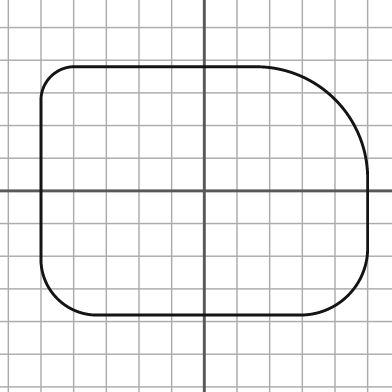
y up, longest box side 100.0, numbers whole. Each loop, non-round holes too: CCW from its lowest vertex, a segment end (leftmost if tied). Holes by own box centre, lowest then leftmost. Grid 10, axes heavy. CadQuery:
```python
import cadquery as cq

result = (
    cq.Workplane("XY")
    .moveTo(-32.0, -38.0)
    .lineTo(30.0, -38.0)
    .threePointArc((44.0, -32.0), (50.0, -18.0))
    .lineTo(50.0, 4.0)
    .threePointArc((40.0, 28.0), (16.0, 38.0))
    .lineTo(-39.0, 38.0)
    .threePointArc((-47.0, 35.0), (-50.0, 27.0))
    .lineTo(-50.0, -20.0)
    .threePointArc((-45.0, -33.0), (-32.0, -38.0))
    .close()
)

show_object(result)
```